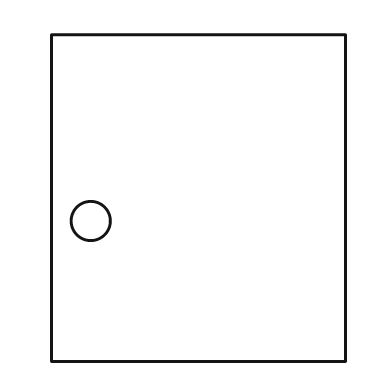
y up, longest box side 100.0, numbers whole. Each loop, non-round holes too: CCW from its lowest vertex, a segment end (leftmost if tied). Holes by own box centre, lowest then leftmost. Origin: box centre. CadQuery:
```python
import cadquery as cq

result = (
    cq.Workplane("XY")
    .moveTo(-45.0, -50.0)
    .lineTo(45.0, -50.0)
    .lineTo(45.0, 50.0)
    .lineTo(-45.0, 50.0)
    .close()
    .moveTo(-33.0, -7.0)
    .circle(6.0)
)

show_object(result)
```